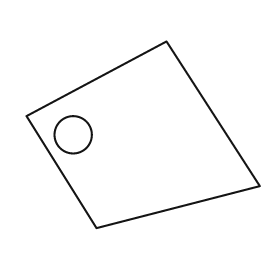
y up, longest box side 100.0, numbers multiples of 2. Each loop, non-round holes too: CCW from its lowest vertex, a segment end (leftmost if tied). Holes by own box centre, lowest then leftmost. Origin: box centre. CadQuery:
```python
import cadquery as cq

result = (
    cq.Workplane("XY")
    .moveTo(-20.0, -40.0)
    .lineTo(50.0, -22.0)
    .lineTo(10.0, 40.0)
    .lineTo(-50.0, 8.0)
    .close()
    .moveTo(-30.0, 0.0)
    .circle(8.0)
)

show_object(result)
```